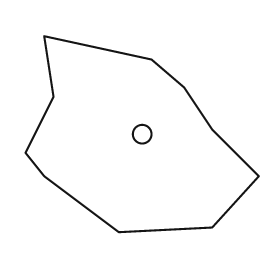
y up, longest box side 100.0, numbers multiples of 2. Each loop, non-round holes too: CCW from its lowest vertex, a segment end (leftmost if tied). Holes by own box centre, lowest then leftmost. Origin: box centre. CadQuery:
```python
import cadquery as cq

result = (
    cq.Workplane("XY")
    .moveTo(-10.0, -42.0)
    .lineTo(30.0, -40.0)
    .lineTo(50.0, -18.0)
    .lineTo(30.0, 2.0)
    .lineTo(18.0, 20.0)
    .lineTo(4.0, 32.0)
    .lineTo(-42.0, 42.0)
    .lineTo(-38.0, 16.0)
    .lineTo(-50.0, -8.0)
    .lineTo(-42.0, -18.0)
    .close()
    .moveTo(0.0, 0.0)
    .circle(4.0)
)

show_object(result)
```